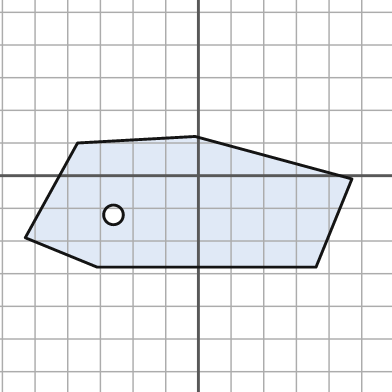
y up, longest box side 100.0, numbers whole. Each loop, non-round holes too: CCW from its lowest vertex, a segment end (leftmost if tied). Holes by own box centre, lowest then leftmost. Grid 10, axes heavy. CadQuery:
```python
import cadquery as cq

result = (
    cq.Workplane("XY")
    .moveTo(-31.0, -28.0)
    .lineTo(36.0, -28.0)
    .lineTo(47.0, -1.0)
    .lineTo(-1.0, 12.0)
    .lineTo(-37.0, 10.0)
    .lineTo(-53.0, -19.0)
    .close()
    .moveTo(-26.0, -12.0)
    .circle(3.0)
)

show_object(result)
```